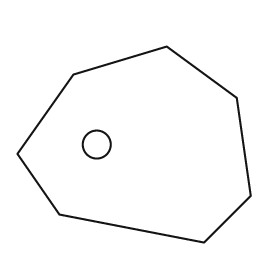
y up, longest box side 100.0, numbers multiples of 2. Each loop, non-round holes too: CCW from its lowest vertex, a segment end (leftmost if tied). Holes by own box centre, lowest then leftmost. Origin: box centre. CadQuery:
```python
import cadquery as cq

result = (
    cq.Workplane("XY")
    .moveTo(30.0, -42.0)
    .lineTo(50.0, -22.0)
    .lineTo(44.0, 20.0)
    .lineTo(14.0, 42.0)
    .lineTo(-26.0, 30.0)
    .lineTo(-50.0, -4.0)
    .lineTo(-32.0, -30.0)
    .close()
    .moveTo(-16.0, 0.0)
    .circle(6.0)
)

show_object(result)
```